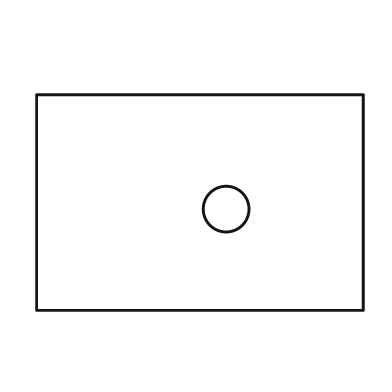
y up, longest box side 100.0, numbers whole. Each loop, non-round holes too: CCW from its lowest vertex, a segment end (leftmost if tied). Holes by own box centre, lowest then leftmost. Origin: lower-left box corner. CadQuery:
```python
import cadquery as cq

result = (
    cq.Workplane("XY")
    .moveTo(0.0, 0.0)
    .lineTo(100.0, 0.0)
    .lineTo(100.0, 66.0)
    .lineTo(0.0, 66.0)
    .close()
    .moveTo(58.0, 31.0)
    .circle(7.0)
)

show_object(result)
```